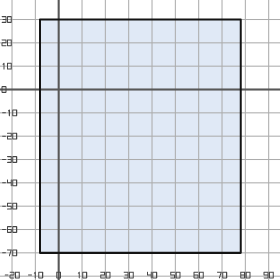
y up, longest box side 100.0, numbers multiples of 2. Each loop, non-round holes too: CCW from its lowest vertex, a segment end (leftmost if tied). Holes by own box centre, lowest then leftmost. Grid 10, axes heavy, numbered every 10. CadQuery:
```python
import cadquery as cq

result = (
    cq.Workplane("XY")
    .moveTo(-8.0, -70.0)
    .lineTo(78.0, -70.0)
    .lineTo(78.0, 30.0)
    .lineTo(-8.0, 30.0)
    .close()
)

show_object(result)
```